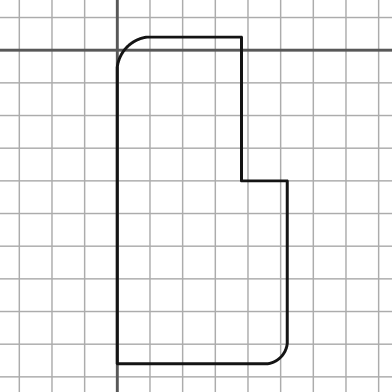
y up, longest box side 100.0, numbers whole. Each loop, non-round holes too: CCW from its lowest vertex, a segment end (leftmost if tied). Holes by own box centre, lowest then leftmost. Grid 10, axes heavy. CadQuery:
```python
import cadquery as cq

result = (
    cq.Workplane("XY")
    .moveTo(0.0, -96.0)
    .lineTo(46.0, -96.0)
    .threePointArc((50.0, -94.0), (52.0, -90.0))
    .lineTo(52.0, -40.0)
    .lineTo(38.0, -40.0)
    .lineTo(38.0, 4.0)
    .lineTo(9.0, 4.0)
    .threePointArc((3.0, 1.0), (0.0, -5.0))
    .close()
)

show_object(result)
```